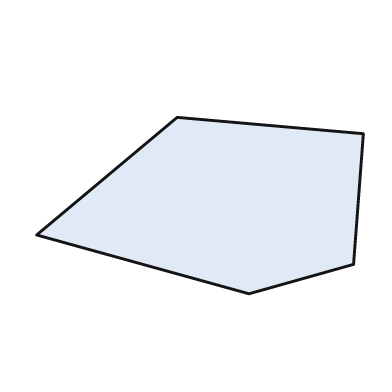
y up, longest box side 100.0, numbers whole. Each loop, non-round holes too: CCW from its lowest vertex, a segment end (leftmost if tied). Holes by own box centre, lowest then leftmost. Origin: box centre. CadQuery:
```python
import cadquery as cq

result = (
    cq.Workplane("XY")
    .moveTo(15.0, -27.0)
    .lineTo(47.0, -18.0)
    .lineTo(50.0, 22.0)
    .lineTo(-7.0, 27.0)
    .lineTo(-50.0, -9.0)
    .close()
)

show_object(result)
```